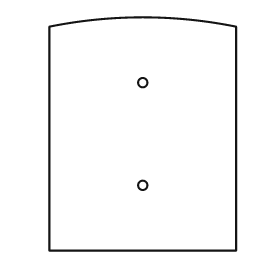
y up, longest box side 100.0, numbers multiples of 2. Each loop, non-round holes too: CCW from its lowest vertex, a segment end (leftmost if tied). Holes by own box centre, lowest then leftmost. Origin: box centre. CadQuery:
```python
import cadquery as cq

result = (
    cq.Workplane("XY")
    .moveTo(-40.0, -50.0)
    .lineTo(40.0, -50.0)
    .lineTo(40.0, 46.0)
    .threePointArc((0.0, 50.0), (-40.0, 46.0))
    .close()
    .moveTo(0.0, -22.0)
    .circle(2.0)
    .moveTo(0.0, 22.0)
    .circle(2.0)
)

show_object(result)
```